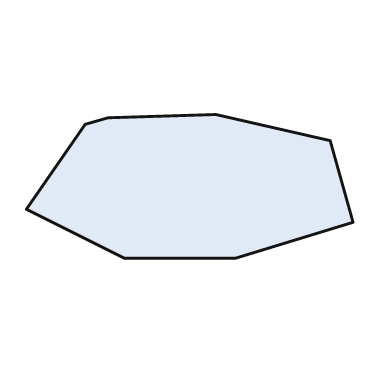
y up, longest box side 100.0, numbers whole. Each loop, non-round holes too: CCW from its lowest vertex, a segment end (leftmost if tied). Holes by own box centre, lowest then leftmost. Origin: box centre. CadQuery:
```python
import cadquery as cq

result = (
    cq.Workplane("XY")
    .moveTo(-20.0, -22.0)
    .lineTo(14.0, -22.0)
    .lineTo(50.0, -11.0)
    .lineTo(43.0, 14.0)
    .lineTo(8.0, 22.0)
    .lineTo(-25.0, 21.0)
    .lineTo(-32.0, 19.0)
    .lineTo(-50.0, -7.0)
    .close()
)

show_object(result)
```